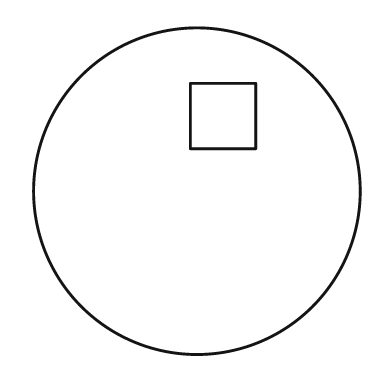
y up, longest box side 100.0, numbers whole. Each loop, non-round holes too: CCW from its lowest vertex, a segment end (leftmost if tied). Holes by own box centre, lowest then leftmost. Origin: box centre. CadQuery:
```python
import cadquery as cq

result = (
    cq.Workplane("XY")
    .moveTo(0.0, 0.0)
    .circle(50.0)
    .moveTo(-2.0, 13.0)
    .lineTo(18.0, 13.0)
    .lineTo(18.0, 33.0)
    .lineTo(-2.0, 33.0)
    .close()
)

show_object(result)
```